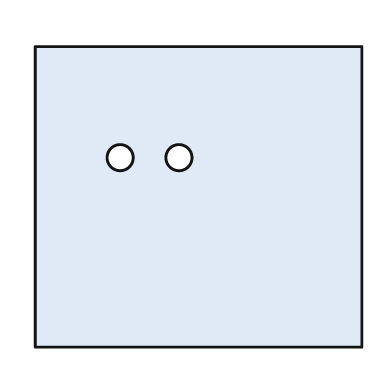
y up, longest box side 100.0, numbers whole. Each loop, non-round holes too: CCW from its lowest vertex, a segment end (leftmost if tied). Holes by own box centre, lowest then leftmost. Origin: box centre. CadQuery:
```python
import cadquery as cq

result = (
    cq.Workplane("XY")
    .moveTo(-50.0, -46.0)
    .lineTo(50.0, -46.0)
    .lineTo(50.0, 46.0)
    .lineTo(-50.0, 46.0)
    .close()
    .moveTo(-24.0, 12.0)
    .circle(4.0)
    .moveTo(-6.0, 12.0)
    .circle(4.0)
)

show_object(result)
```